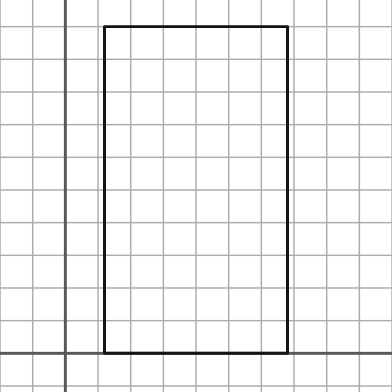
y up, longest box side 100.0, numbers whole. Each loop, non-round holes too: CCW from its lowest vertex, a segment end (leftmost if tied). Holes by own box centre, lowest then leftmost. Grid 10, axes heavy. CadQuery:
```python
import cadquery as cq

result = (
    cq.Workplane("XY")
    .moveTo(12.0, 0.0)
    .lineTo(68.0, 0.0)
    .lineTo(68.0, 100.0)
    .lineTo(12.0, 100.0)
    .close()
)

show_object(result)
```